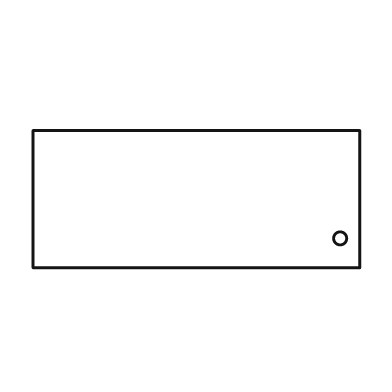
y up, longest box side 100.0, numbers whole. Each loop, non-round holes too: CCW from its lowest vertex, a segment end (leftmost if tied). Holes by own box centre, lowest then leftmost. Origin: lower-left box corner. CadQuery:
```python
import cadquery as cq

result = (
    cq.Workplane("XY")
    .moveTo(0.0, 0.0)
    .lineTo(100.0, 0.0)
    .lineTo(100.0, 42.0)
    .lineTo(0.0, 42.0)
    .close()
    .moveTo(94.0, 9.0)
    .circle(2.0)
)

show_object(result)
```